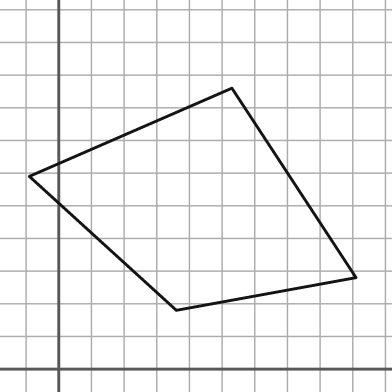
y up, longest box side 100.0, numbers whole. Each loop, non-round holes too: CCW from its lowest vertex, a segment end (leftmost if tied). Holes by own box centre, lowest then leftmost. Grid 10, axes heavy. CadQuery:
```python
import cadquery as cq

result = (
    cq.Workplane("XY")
    .moveTo(36.0, 18.0)
    .lineTo(91.0, 28.0)
    .lineTo(53.0, 86.0)
    .lineTo(-9.0, 59.0)
    .close()
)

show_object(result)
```